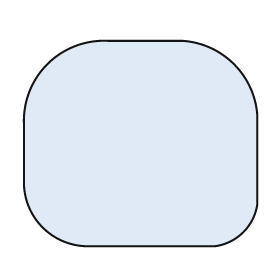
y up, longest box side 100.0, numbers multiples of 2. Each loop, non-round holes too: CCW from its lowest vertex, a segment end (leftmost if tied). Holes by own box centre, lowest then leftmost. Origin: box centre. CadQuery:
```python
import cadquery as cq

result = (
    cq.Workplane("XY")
    .moveTo(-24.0, -44.0)
    .lineTo(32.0, -44.0)
    .threePointArc((44.0, -38.0), (50.0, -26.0))
    .lineTo(50.0, 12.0)
    .threePointArc((40.0, 34.0), (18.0, 44.0))
    .lineTo(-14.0, 44.0)
    .threePointArc((-40.0, 34.0), (-50.0, 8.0))
    .lineTo(-50.0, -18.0)
    .threePointArc((-42.0, -36.0), (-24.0, -44.0))
    .close()
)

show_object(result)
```